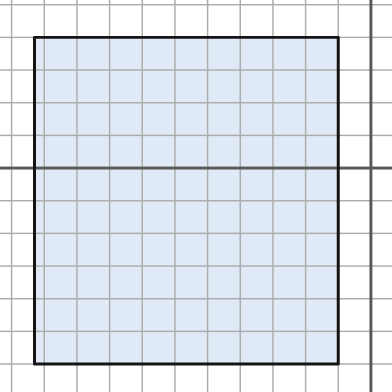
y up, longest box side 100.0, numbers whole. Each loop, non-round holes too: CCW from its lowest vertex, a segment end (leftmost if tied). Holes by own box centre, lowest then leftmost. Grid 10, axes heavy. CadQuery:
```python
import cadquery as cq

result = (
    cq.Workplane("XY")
    .moveTo(-103.0, -60.0)
    .lineTo(-10.0, -60.0)
    .lineTo(-10.0, 40.0)
    .lineTo(-103.0, 40.0)
    .close()
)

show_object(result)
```